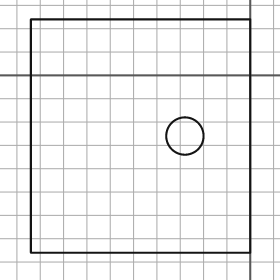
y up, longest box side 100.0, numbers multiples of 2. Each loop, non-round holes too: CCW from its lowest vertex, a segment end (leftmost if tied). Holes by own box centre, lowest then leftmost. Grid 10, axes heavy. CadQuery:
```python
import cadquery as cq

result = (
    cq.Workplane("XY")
    .moveTo(-94.0, -76.0)
    .lineTo(0.0, -76.0)
    .lineTo(0.0, 24.0)
    .lineTo(-94.0, 24.0)
    .close()
    .moveTo(-28.0, -26.0)
    .circle(8.0)
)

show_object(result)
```